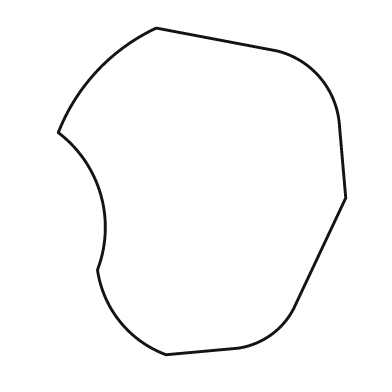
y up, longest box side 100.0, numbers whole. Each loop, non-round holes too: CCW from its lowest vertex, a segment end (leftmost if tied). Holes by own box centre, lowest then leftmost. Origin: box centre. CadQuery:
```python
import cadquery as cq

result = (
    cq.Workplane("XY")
    .moveTo(-11.0, -50.0)
    .lineTo(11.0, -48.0)
    .threePointArc((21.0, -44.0), (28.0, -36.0))
    .lineTo(44.0, -2.0)
    .lineTo(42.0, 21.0)
    .threePointArc((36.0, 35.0), (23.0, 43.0))
    .lineTo(-14.0, 50.0)
    .threePointArc((-32.0, 37.0), (-44.0, 18.0))
    .threePointArc((-31.0, -1.0), (-32.0, -24.0))
    .threePointArc((-25.0, -40.0), (-11.0, -50.0))
    .close()
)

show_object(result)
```